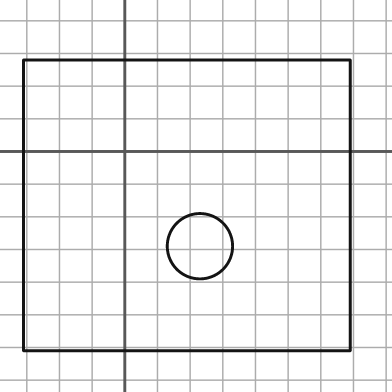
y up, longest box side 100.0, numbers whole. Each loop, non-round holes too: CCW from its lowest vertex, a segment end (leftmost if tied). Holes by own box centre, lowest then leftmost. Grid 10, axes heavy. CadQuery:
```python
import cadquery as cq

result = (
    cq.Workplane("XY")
    .moveTo(-31.0, -61.0)
    .lineTo(69.0, -61.0)
    .lineTo(69.0, 28.0)
    .lineTo(-31.0, 28.0)
    .close()
    .moveTo(23.0, -29.0)
    .circle(10.0)
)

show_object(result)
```